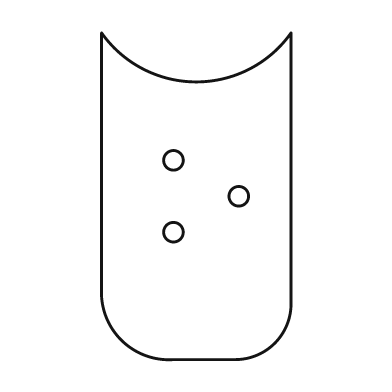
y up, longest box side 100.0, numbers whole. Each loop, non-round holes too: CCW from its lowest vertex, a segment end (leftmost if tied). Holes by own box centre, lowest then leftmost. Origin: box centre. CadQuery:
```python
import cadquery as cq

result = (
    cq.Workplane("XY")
    .moveTo(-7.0, -50.0)
    .lineTo(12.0, -50.0)
    .threePointArc((24.0, -45.0), (29.0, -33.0))
    .lineTo(29.0, 50.0)
    .threePointArc((0.0, 35.0), (-29.0, 50.0))
    .lineTo(-29.0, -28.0)
    .threePointArc((-23.0, -44.0), (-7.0, -50.0))
    .close()
    .moveTo(-7.0, -11.0)
    .circle(3.0)
    .moveTo(13.0, 0.0)
    .circle(3.0)
    .moveTo(-7.0, 11.0)
    .circle(3.0)
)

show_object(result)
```